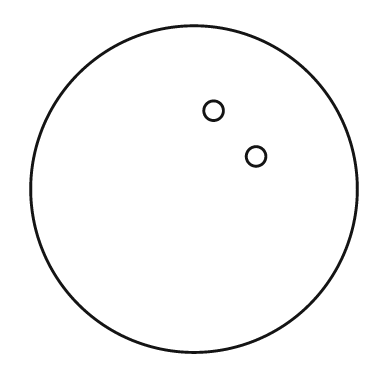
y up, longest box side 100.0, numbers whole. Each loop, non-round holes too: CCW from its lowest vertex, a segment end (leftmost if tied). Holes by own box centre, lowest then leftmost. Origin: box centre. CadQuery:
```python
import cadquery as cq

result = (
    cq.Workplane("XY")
    .moveTo(0.0, 0.0)
    .circle(50.0)
    .moveTo(19.0, 10.0)
    .circle(3.0)
    .moveTo(6.0, 24.0)
    .circle(3.0)
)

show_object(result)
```